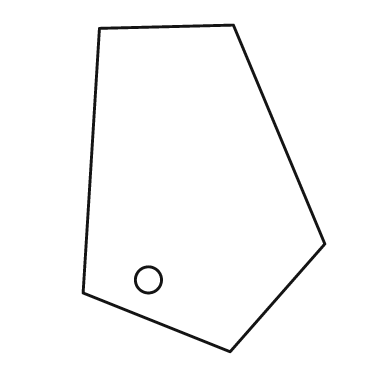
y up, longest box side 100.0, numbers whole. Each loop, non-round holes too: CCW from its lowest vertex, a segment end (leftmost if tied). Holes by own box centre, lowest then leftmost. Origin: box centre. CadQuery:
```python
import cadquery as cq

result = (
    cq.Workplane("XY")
    .moveTo(8.0, -50.0)
    .lineTo(37.0, -17.0)
    .lineTo(9.0, 50.0)
    .lineTo(-32.0, 49.0)
    .lineTo(-37.0, -32.0)
    .close()
    .moveTo(-17.0, -28.0)
    .circle(4.0)
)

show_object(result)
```